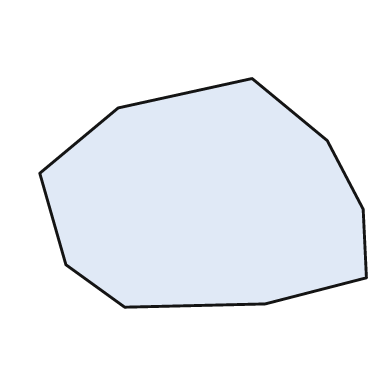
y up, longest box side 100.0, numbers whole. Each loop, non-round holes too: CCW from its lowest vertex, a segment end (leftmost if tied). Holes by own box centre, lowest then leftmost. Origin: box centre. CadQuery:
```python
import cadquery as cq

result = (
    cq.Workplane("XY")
    .moveTo(-24.0, -35.0)
    .lineTo(19.0, -34.0)
    .lineTo(50.0, -26.0)
    .lineTo(49.0, -5.0)
    .lineTo(38.0, 16.0)
    .lineTo(15.0, 35.0)
    .lineTo(-26.0, 26.0)
    .lineTo(-50.0, 6.0)
    .lineTo(-42.0, -22.0)
    .close()
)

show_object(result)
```